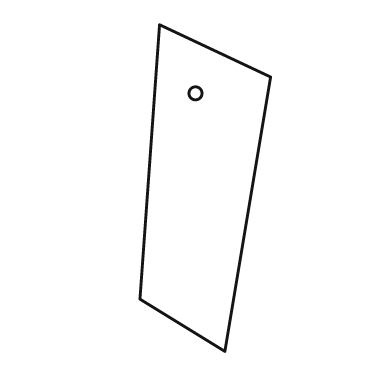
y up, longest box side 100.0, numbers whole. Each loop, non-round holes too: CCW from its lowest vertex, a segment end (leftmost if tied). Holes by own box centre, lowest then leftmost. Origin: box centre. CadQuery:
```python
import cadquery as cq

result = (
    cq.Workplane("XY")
    .moveTo(6.0, -50.0)
    .lineTo(20.0, 34.0)
    .lineTo(-14.0, 50.0)
    .lineTo(-20.0, -34.0)
    .close()
    .moveTo(-3.0, 29.0)
    .circle(2.0)
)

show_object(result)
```